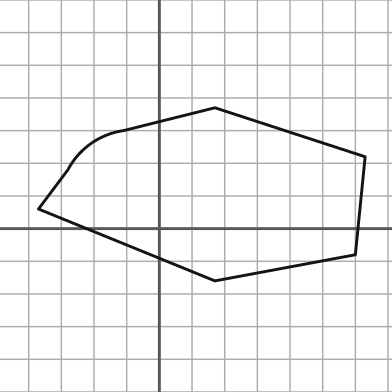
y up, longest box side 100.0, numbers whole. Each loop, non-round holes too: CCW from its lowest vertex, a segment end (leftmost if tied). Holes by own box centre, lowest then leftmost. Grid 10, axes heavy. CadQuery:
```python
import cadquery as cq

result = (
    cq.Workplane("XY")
    .moveTo(17.0, -16.0)
    .lineTo(60.0, -8.0)
    .lineTo(63.0, 22.0)
    .lineTo(17.0, 37.0)
    .lineTo(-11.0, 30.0)
    .threePointArc((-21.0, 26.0), (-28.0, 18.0))
    .lineTo(-37.0, 6.0)
    .close()
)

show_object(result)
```